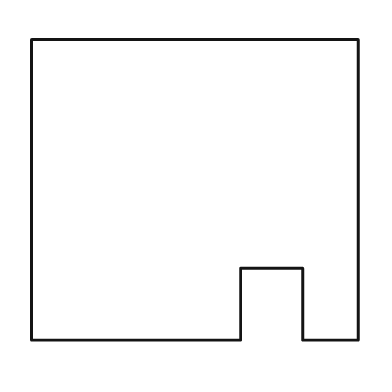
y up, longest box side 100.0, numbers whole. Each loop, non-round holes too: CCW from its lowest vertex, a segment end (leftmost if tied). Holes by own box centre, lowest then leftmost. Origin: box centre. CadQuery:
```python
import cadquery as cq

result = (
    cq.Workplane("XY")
    .moveTo(-50.0, -46.0)
    .lineTo(14.0, -46.0)
    .lineTo(14.0, -24.0)
    .lineTo(33.0, -24.0)
    .lineTo(33.0, -46.0)
    .lineTo(50.0, -46.0)
    .lineTo(50.0, 46.0)
    .lineTo(-50.0, 46.0)
    .close()
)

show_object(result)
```